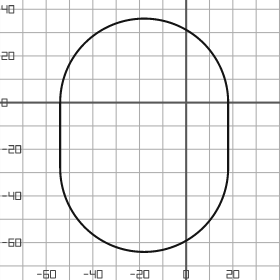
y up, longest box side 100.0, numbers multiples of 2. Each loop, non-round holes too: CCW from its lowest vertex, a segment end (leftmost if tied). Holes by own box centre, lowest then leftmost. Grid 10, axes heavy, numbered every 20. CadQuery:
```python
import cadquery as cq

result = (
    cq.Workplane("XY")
    .moveTo(-54.0, -28.0)
    .threePointArc((-18.0, -64.0), (18.0, -28.0))
    .lineTo(18.0, 0.0)
    .threePointArc((-18.0, 36.0), (-54.0, 0.0))
    .close()
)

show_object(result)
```